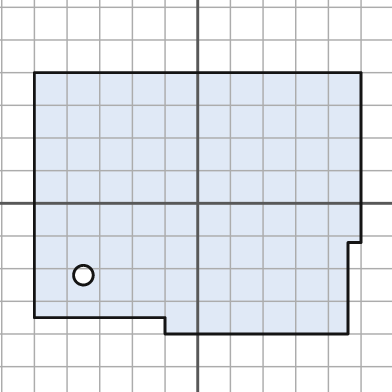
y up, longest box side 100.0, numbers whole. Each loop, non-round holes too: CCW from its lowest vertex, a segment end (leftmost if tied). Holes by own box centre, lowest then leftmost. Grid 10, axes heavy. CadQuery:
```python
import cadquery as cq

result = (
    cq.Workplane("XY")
    .moveTo(-10.0, -40.0)
    .lineTo(46.0, -40.0)
    .lineTo(46.0, -12.0)
    .lineTo(50.0, -12.0)
    .lineTo(50.0, 40.0)
    .lineTo(-50.0, 40.0)
    .lineTo(-50.0, -35.0)
    .lineTo(-10.0, -35.0)
    .close()
    .moveTo(-35.0, -22.0)
    .circle(3.0)
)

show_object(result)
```